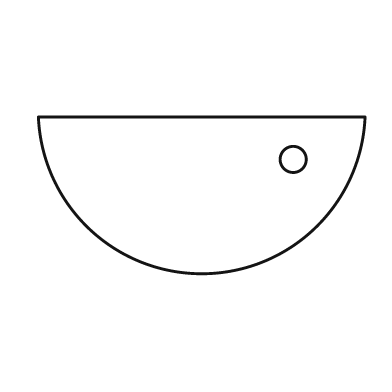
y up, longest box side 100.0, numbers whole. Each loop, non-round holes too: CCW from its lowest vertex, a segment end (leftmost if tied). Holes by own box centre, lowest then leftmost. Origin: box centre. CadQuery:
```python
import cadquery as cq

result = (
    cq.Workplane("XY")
    .moveTo(-50.0, 24.0)
    .threePointArc((0.0, -24.0), (50.0, 24.0))
    .close()
    .moveTo(28.0, 11.0)
    .circle(4.0)
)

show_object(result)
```